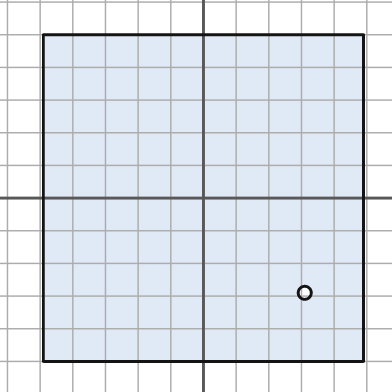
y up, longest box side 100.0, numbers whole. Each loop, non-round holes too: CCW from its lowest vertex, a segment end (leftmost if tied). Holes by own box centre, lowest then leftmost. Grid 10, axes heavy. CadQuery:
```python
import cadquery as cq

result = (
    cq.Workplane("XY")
    .moveTo(-49.0, -50.0)
    .lineTo(49.0, -50.0)
    .lineTo(49.0, 50.0)
    .lineTo(-49.0, 50.0)
    .close()
    .moveTo(31.0, -29.0)
    .circle(2.0)
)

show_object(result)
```